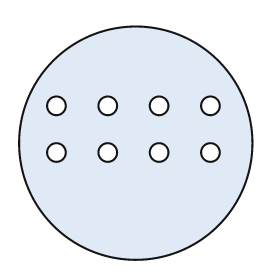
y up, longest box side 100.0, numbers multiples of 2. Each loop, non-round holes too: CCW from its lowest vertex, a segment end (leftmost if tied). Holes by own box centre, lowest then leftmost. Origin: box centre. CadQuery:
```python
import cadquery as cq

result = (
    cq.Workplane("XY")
    .moveTo(0.0, 0.0)
    .circle(50.0)
    .moveTo(-34.0, -4.0)
    .circle(4.0)
    .moveTo(-12.0, -4.0)
    .circle(4.0)
    .moveTo(10.0, -4.0)
    .circle(4.0)
    .moveTo(32.0, -4.0)
    .circle(4.0)
    .moveTo(-34.0, 16.0)
    .circle(4.0)
    .moveTo(-12.0, 16.0)
    .circle(4.0)
    .moveTo(10.0, 16.0)
    .circle(4.0)
    .moveTo(32.0, 16.0)
    .circle(4.0)
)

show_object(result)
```